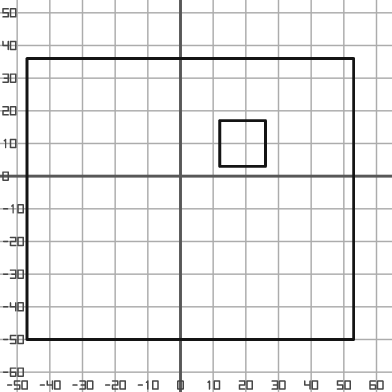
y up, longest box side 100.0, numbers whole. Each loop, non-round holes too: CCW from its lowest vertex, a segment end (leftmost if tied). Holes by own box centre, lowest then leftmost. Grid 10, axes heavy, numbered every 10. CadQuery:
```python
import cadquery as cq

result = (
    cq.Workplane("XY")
    .moveTo(-47.0, -50.0)
    .lineTo(53.0, -50.0)
    .lineTo(53.0, 36.0)
    .lineTo(-47.0, 36.0)
    .close()
    .moveTo(12.0, 3.0)
    .lineTo(26.0, 3.0)
    .lineTo(26.0, 17.0)
    .lineTo(12.0, 17.0)
    .close()
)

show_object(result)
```